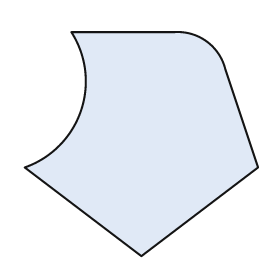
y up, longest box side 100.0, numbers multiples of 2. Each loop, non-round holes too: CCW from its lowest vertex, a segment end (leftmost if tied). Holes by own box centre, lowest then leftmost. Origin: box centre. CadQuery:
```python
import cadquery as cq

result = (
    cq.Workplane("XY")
    .moveTo(0.0, -48.0)
    .lineTo(50.0, -10.0)
    .lineTo(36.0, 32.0)
    .threePointArc((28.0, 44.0), (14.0, 48.0))
    .lineTo(-30.0, 48.0)
    .threePointArc((-26.0, 14.0), (-50.0, -10.0))
    .close()
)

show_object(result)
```